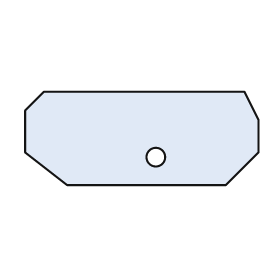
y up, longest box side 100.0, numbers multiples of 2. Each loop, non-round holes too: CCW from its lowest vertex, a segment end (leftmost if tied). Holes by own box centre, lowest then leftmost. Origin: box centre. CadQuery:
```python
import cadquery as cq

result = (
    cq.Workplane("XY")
    .moveTo(-32.0, -20.0)
    .lineTo(36.0, -20.0)
    .lineTo(50.0, -6.0)
    .lineTo(50.0, 8.0)
    .lineTo(44.0, 20.0)
    .lineTo(-42.0, 20.0)
    .lineTo(-50.0, 12.0)
    .lineTo(-50.0, -6.0)
    .close()
    .moveTo(6.0, -8.0)
    .circle(4.0)
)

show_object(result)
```